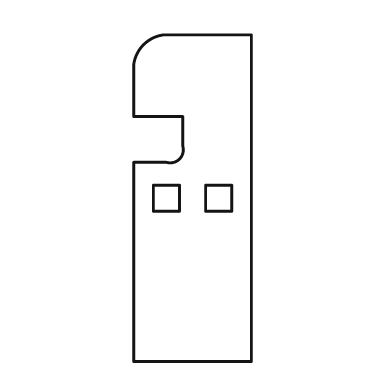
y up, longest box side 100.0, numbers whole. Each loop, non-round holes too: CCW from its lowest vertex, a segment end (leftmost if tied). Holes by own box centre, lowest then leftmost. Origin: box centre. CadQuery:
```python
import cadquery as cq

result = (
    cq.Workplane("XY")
    .moveTo(-18.0, -50.0)
    .lineTo(18.0, -50.0)
    .lineTo(18.0, 50.0)
    .lineTo(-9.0, 50.0)
    .threePointArc((-15.0, 47.0), (-18.0, 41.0))
    .lineTo(-18.0, 25.0)
    .lineTo(-3.0, 25.0)
    .lineTo(-3.0, 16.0)
    .threePointArc((-4.0, 12.0), (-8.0, 11.0))
    .lineTo(-18.0, 11.0)
    .close()
    .moveTo(-12.0, -4.0)
    .lineTo(-4.0, -4.0)
    .lineTo(-4.0, 4.0)
    .lineTo(-12.0, 4.0)
    .close()
    .moveTo(4.0, -4.0)
    .lineTo(12.0, -4.0)
    .lineTo(12.0, 4.0)
    .lineTo(4.0, 4.0)
    .close()
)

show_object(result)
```